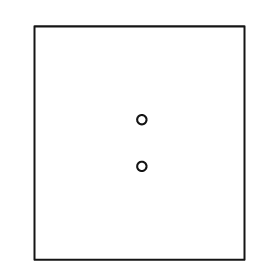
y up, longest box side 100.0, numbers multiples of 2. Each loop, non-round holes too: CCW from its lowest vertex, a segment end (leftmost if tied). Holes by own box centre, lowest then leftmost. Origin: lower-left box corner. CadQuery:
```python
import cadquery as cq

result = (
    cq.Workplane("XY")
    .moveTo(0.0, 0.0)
    .lineTo(90.0, 0.0)
    .lineTo(90.0, 100.0)
    .lineTo(0.0, 100.0)
    .close()
    .moveTo(46.0, 40.0)
    .circle(2.0)
    .moveTo(46.0, 60.0)
    .circle(2.0)
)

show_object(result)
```